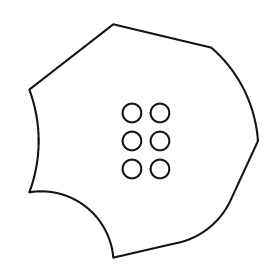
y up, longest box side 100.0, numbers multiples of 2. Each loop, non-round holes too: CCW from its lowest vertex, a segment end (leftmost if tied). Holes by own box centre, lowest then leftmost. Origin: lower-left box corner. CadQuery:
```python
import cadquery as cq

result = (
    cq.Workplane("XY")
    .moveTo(36.0, 0.0)
    .lineTo(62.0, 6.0)
    .threePointArc((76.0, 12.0), (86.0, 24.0))
    .lineTo(98.0, 50.0)
    .threePointArc((92.0, 72.0), (78.0, 90.0))
    .lineTo(36.0, 100.0)
    .lineTo(0.0, 72.0)
    .threePointArc((4.0, 50.0), (0.0, 28.0))
    .threePointArc((24.0, 22.0), (36.0, 0.0))
    .close()
    .moveTo(44.0, 38.0)
    .circle(4.0)
    .moveTo(56.0, 38.0)
    .circle(4.0)
    .moveTo(44.0, 50.0)
    .circle(4.0)
    .moveTo(56.0, 50.0)
    .circle(4.0)
    .moveTo(44.0, 62.0)
    .circle(4.0)
    .moveTo(56.0, 62.0)
    .circle(4.0)
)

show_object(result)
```